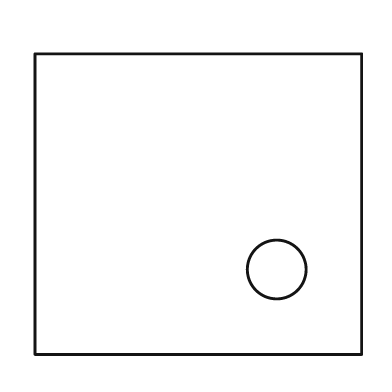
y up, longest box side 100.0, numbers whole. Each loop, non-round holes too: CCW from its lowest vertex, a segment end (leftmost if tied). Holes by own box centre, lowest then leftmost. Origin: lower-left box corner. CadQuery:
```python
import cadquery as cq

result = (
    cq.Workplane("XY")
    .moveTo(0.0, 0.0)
    .lineTo(100.0, 0.0)
    .lineTo(100.0, 92.0)
    .lineTo(0.0, 92.0)
    .close()
    .moveTo(74.0, 26.0)
    .circle(9.0)
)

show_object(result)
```